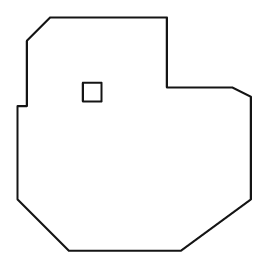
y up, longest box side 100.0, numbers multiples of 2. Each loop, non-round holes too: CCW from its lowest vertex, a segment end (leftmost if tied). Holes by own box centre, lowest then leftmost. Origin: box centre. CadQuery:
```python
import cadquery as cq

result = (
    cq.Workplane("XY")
    .moveTo(-28.0, -50.0)
    .lineTo(20.0, -50.0)
    .lineTo(50.0, -28.0)
    .lineTo(50.0, 16.0)
    .lineTo(42.0, 20.0)
    .lineTo(14.0, 20.0)
    .lineTo(14.0, 50.0)
    .lineTo(-36.0, 50.0)
    .lineTo(-46.0, 40.0)
    .lineTo(-46.0, 12.0)
    .lineTo(-50.0, 12.0)
    .lineTo(-50.0, -28.0)
    .close()
    .moveTo(-22.0, 14.0)
    .lineTo(-14.0, 14.0)
    .lineTo(-14.0, 22.0)
    .lineTo(-22.0, 22.0)
    .close()
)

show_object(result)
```